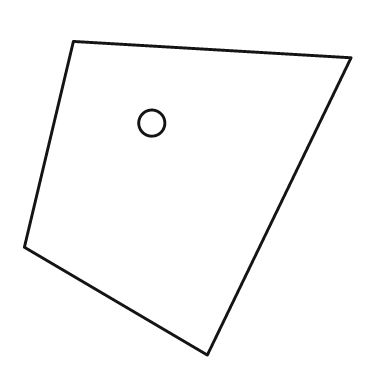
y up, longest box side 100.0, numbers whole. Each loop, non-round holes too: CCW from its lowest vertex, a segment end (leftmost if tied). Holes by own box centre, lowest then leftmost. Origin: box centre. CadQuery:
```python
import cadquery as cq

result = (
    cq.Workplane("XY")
    .moveTo(6.0, -48.0)
    .lineTo(50.0, 43.0)
    .lineTo(-35.0, 48.0)
    .lineTo(-50.0, -15.0)
    .close()
    .moveTo(-11.0, 23.0)
    .circle(4.0)
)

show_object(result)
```